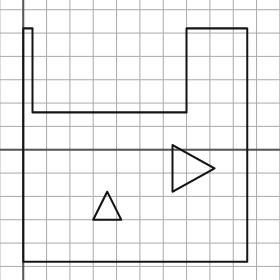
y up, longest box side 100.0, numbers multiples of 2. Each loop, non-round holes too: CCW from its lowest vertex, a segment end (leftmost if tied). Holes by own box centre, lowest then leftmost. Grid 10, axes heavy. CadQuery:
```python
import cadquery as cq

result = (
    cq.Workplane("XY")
    .moveTo(0.0, -48.0)
    .lineTo(96.0, -48.0)
    .lineTo(96.0, 52.0)
    .lineTo(70.0, 52.0)
    .lineTo(70.0, 16.0)
    .lineTo(4.0, 16.0)
    .lineTo(4.0, 52.0)
    .lineTo(0.0, 52.0)
    .close()
    .moveTo(30.0, -30.0)
    .lineTo(42.0, -30.0)
    .lineTo(36.0, -18.0)
    .close()
    .moveTo(64.0, -18.0)
    .lineTo(82.0, -8.0)
    .lineTo(64.0, 2.0)
    .close()
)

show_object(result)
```